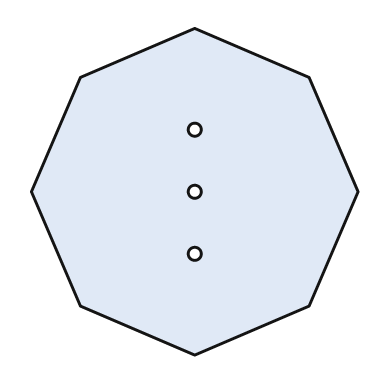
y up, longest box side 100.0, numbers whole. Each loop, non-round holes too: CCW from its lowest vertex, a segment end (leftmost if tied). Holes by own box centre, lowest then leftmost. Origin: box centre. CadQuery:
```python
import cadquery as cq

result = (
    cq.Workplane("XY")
    .moveTo(0.0, -50.0)
    .lineTo(35.0, -35.0)
    .lineTo(50.0, 0.0)
    .lineTo(35.0, 35.0)
    .lineTo(0.0, 50.0)
    .lineTo(-35.0, 35.0)
    .lineTo(-50.0, 0.0)
    .lineTo(-35.0, -35.0)
    .close()
    .moveTo(0.0, -19.0)
    .circle(2.0)
    .moveTo(0.0, 0.0)
    .circle(2.0)
    .moveTo(0.0, 19.0)
    .circle(2.0)
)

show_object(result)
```